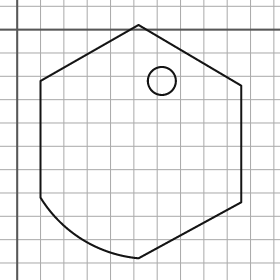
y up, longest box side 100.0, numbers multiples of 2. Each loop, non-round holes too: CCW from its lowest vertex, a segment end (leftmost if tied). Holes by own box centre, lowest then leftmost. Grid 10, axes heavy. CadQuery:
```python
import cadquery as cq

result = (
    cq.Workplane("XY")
    .moveTo(52.0, -98.0)
    .lineTo(96.0, -74.0)
    .lineTo(96.0, -24.0)
    .lineTo(52.0, 2.0)
    .lineTo(10.0, -22.0)
    .lineTo(10.0, -72.0)
    .threePointArc((28.0, -90.0), (52.0, -98.0))
    .close()
    .moveTo(62.0, -22.0)
    .circle(6.0)
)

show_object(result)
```